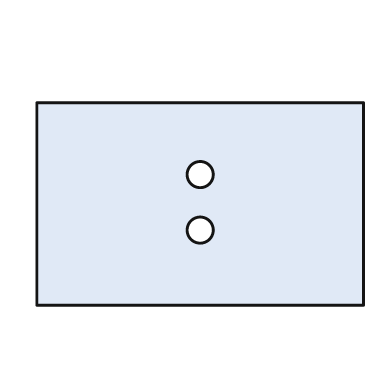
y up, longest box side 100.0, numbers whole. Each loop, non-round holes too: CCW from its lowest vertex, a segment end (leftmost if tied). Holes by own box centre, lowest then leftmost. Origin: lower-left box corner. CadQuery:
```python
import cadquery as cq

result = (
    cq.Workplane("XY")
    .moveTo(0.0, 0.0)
    .lineTo(100.0, 0.0)
    .lineTo(100.0, 62.0)
    .lineTo(0.0, 62.0)
    .close()
    .moveTo(50.0, 23.0)
    .circle(4.0)
    .moveTo(50.0, 40.0)
    .circle(4.0)
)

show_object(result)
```